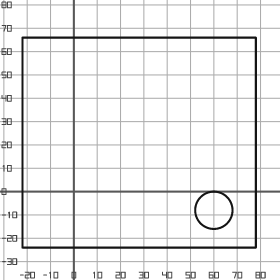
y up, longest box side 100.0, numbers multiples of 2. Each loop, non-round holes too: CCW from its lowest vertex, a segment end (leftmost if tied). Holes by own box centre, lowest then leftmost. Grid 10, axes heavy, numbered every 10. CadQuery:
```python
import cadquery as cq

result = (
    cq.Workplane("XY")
    .moveTo(-22.0, -24.0)
    .lineTo(78.0, -24.0)
    .lineTo(78.0, 66.0)
    .lineTo(-22.0, 66.0)
    .close()
    .moveTo(60.0, -8.0)
    .circle(8.0)
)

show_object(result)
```